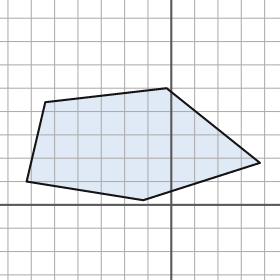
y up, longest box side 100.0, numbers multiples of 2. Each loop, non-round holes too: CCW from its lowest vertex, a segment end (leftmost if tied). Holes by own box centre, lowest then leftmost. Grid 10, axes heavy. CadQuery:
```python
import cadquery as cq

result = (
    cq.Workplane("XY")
    .moveTo(-12.0, 2.0)
    .lineTo(38.0, 18.0)
    .lineTo(-2.0, 50.0)
    .lineTo(-54.0, 44.0)
    .lineTo(-62.0, 10.0)
    .close()
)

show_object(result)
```